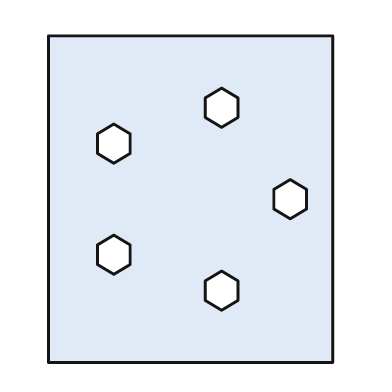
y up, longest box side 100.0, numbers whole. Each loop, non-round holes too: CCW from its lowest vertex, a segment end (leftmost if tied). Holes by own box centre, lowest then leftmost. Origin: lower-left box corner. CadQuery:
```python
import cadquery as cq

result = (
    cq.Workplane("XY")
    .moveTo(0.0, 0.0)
    .lineTo(87.0, 0.0)
    .lineTo(87.0, 100.0)
    .lineTo(0.0, 100.0)
    .close()
    .moveTo(53.0, 16.0)
    .lineTo(58.0, 19.0)
    .lineTo(58.0, 25.0)
    .lineTo(53.0, 28.0)
    .lineTo(48.0, 25.0)
    .lineTo(48.0, 19.0)
    .close()
    .moveTo(20.0, 27.0)
    .lineTo(25.0, 30.0)
    .lineTo(25.0, 36.0)
    .lineTo(20.0, 39.0)
    .lineTo(15.0, 36.0)
    .lineTo(15.0, 30.0)
    .close()
    .moveTo(74.0, 44.0)
    .lineTo(79.0, 47.0)
    .lineTo(79.0, 53.0)
    .lineTo(74.0, 56.0)
    .lineTo(69.0, 53.0)
    .lineTo(69.0, 47.0)
    .close()
    .moveTo(20.0, 61.0)
    .lineTo(25.0, 64.0)
    .lineTo(25.0, 70.0)
    .lineTo(20.0, 73.0)
    .lineTo(15.0, 70.0)
    .lineTo(15.0, 64.0)
    .close()
    .moveTo(53.0, 72.0)
    .lineTo(58.0, 75.0)
    .lineTo(58.0, 81.0)
    .lineTo(53.0, 84.0)
    .lineTo(48.0, 81.0)
    .lineTo(48.0, 75.0)
    .close()
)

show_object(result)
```